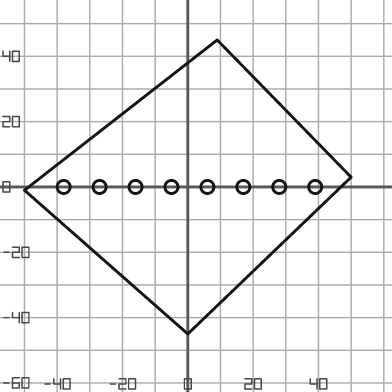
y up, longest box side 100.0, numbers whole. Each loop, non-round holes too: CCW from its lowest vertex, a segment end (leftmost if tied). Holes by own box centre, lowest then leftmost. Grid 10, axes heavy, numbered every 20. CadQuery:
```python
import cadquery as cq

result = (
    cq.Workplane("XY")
    .moveTo(0.0, -45.0)
    .lineTo(50.0, 3.0)
    .lineTo(9.0, 45.0)
    .lineTo(-50.0, -1.0)
    .close()
    .moveTo(-38.0, 0.0)
    .circle(2.0)
    .moveTo(-27.0, 0.0)
    .circle(2.0)
    .moveTo(-16.0, 0.0)
    .circle(2.0)
    .moveTo(-5.0, 0.0)
    .circle(2.0)
    .moveTo(6.0, 0.0)
    .circle(2.0)
    .moveTo(17.0, 0.0)
    .circle(2.0)
    .moveTo(28.0, 0.0)
    .circle(2.0)
    .moveTo(39.0, 0.0)
    .circle(2.0)
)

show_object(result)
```